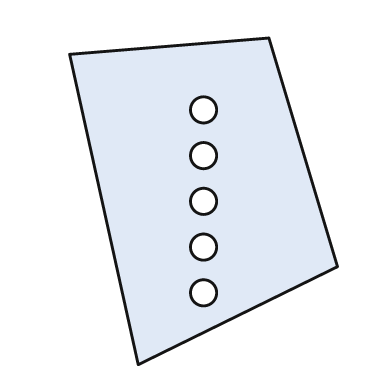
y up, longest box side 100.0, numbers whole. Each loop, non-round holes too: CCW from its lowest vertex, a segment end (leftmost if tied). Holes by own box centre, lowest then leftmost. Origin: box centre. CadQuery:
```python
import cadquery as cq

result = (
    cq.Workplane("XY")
    .moveTo(-20.0, -50.0)
    .lineTo(41.0, -20.0)
    .lineTo(20.0, 50.0)
    .lineTo(-41.0, 45.0)
    .close()
    .moveTo(0.0, -28.0)
    .circle(4.0)
    .moveTo(0.0, -14.0)
    .circle(4.0)
    .moveTo(0.0, 0.0)
    .circle(4.0)
    .moveTo(0.0, 14.0)
    .circle(4.0)
    .moveTo(0.0, 28.0)
    .circle(4.0)
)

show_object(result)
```